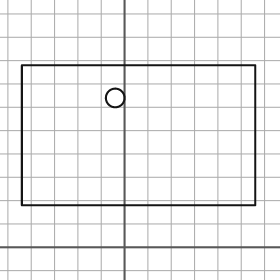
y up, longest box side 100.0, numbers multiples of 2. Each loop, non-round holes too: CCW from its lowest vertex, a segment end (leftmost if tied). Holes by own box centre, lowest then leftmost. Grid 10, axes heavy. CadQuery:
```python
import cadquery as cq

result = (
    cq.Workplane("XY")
    .moveTo(-44.0, 18.0)
    .lineTo(56.0, 18.0)
    .lineTo(56.0, 78.0)
    .lineTo(-44.0, 78.0)
    .close()
    .moveTo(-4.0, 64.0)
    .circle(4.0)
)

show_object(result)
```